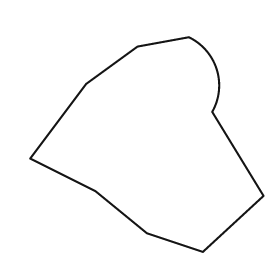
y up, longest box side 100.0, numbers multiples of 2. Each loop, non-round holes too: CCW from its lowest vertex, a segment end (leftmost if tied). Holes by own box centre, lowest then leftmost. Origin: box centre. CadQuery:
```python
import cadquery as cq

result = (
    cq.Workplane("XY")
    .moveTo(24.0, -46.0)
    .lineTo(50.0, -22.0)
    .lineTo(28.0, 14.0)
    .threePointArc((30.0, 32.0), (18.0, 46.0))
    .lineTo(-4.0, 42.0)
    .lineTo(-26.0, 26.0)
    .lineTo(-50.0, -6.0)
    .lineTo(-22.0, -20.0)
    .lineTo(0.0, -38.0)
    .close()
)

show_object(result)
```